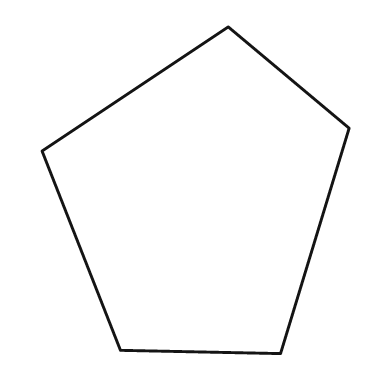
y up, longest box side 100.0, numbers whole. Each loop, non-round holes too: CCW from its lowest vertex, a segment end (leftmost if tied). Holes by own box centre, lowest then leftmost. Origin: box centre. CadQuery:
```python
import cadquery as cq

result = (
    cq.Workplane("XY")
    .moveTo(26.0, -50.0)
    .lineTo(47.0, 19.0)
    .lineTo(10.0, 50.0)
    .lineTo(-47.0, 12.0)
    .lineTo(-23.0, -49.0)
    .close()
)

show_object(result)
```